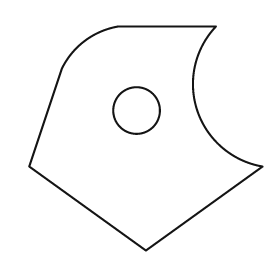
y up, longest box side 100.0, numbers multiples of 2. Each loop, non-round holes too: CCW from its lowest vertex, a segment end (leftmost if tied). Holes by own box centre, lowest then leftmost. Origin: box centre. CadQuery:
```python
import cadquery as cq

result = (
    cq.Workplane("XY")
    .moveTo(0.0, -48.0)
    .lineTo(50.0, -12.0)
    .threePointArc((22.0, 12.0), (30.0, 48.0))
    .lineTo(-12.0, 48.0)
    .threePointArc((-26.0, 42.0), (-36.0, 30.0))
    .lineTo(-50.0, -12.0)
    .close()
    .moveTo(-4.0, 12.0)
    .circle(10.0)
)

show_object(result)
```